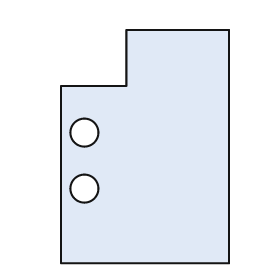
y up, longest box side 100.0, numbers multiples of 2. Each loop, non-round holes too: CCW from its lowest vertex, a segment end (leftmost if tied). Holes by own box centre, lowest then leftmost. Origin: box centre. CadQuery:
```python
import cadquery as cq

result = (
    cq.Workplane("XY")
    .moveTo(-36.0, -50.0)
    .lineTo(36.0, -50.0)
    .lineTo(36.0, 50.0)
    .lineTo(-8.0, 50.0)
    .lineTo(-8.0, 26.0)
    .lineTo(-36.0, 26.0)
    .close()
    .moveTo(-26.0, -18.0)
    .circle(6.0)
    .moveTo(-26.0, 6.0)
    .circle(6.0)
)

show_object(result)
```